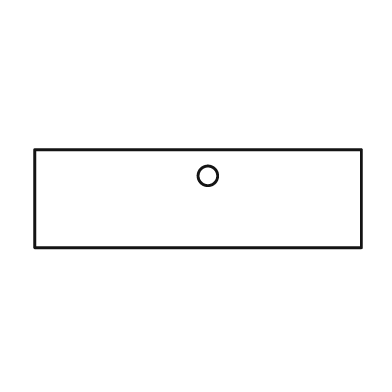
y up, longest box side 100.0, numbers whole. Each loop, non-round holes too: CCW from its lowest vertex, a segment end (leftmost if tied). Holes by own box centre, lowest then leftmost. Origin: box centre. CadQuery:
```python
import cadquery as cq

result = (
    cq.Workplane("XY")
    .moveTo(-50.0, -15.0)
    .lineTo(50.0, -15.0)
    .lineTo(50.0, 15.0)
    .lineTo(-50.0, 15.0)
    .close()
    .moveTo(3.0, 7.0)
    .circle(3.0)
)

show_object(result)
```